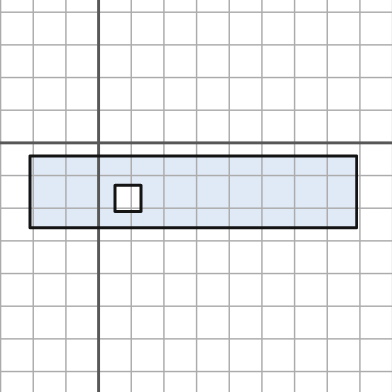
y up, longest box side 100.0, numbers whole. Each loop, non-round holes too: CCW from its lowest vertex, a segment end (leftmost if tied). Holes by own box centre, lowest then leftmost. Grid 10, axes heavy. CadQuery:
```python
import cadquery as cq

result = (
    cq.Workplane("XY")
    .moveTo(-21.0, -26.0)
    .lineTo(79.0, -26.0)
    .lineTo(79.0, -4.0)
    .lineTo(-21.0, -4.0)
    .close()
    .moveTo(5.0, -21.0)
    .lineTo(13.0, -21.0)
    .lineTo(13.0, -13.0)
    .lineTo(5.0, -13.0)
    .close()
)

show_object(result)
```